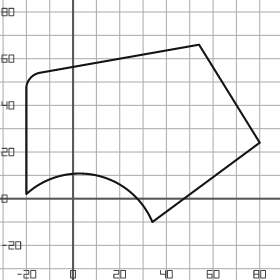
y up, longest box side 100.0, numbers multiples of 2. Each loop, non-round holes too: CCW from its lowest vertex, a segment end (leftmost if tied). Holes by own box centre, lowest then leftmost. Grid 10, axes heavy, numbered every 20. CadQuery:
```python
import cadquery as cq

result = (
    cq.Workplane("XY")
    .moveTo(34.0, -10.0)
    .lineTo(80.0, 24.0)
    .lineTo(54.0, 66.0)
    .lineTo(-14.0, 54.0)
    .threePointArc((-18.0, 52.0), (-20.0, 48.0))
    .lineTo(-20.0, 2.0)
    .threePointArc((10.0, 10.0), (34.0, -10.0))
    .close()
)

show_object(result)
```